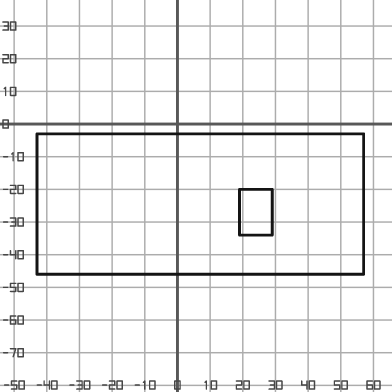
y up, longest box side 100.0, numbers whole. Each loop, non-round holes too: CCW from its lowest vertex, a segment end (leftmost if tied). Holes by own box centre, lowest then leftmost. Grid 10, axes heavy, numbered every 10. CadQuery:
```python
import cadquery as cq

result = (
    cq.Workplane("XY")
    .moveTo(-43.0, -46.0)
    .lineTo(57.0, -46.0)
    .lineTo(57.0, -3.0)
    .lineTo(-43.0, -3.0)
    .close()
    .moveTo(19.0, -34.0)
    .lineTo(29.0, -34.0)
    .lineTo(29.0, -20.0)
    .lineTo(19.0, -20.0)
    .close()
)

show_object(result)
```